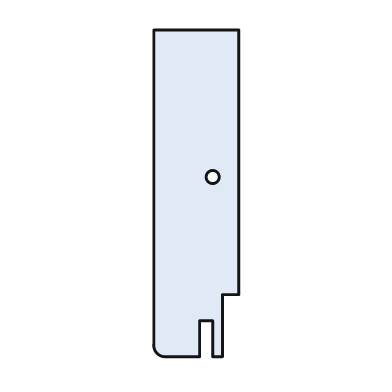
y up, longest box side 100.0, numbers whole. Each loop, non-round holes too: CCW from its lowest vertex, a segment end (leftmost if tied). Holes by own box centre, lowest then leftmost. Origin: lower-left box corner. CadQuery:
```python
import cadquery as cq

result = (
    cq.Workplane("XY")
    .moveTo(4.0, 0.0)
    .lineTo(14.0, 0.0)
    .lineTo(14.0, 11.0)
    .lineTo(18.0, 11.0)
    .lineTo(18.0, 0.0)
    .lineTo(21.0, 0.0)
    .lineTo(21.0, 19.0)
    .lineTo(26.0, 19.0)
    .lineTo(26.0, 100.0)
    .lineTo(0.0, 100.0)
    .lineTo(0.0, 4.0)
    .threePointArc((1.0, 1.0), (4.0, 0.0))
    .close()
    .moveTo(18.0, 55.0)
    .circle(2.0)
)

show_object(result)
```